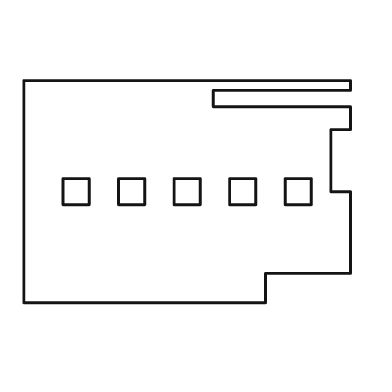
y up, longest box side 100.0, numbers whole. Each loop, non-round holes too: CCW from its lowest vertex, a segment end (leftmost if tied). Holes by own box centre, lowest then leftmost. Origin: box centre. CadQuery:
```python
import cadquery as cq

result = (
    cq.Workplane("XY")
    .moveTo(-50.0, -34.0)
    .lineTo(24.0, -34.0)
    .lineTo(24.0, -25.0)
    .lineTo(50.0, -25.0)
    .lineTo(50.0, 0.0)
    .lineTo(44.0, 0.0)
    .lineTo(44.0, 19.0)
    .lineTo(50.0, 19.0)
    .lineTo(50.0, 26.0)
    .lineTo(8.0, 26.0)
    .lineTo(8.0, 31.0)
    .lineTo(50.0, 31.0)
    .lineTo(50.0, 34.0)
    .lineTo(-50.0, 34.0)
    .close()
    .moveTo(-38.0, -4.0)
    .lineTo(-30.0, -4.0)
    .lineTo(-30.0, 4.0)
    .lineTo(-38.0, 4.0)
    .close()
    .moveTo(-21.0, -4.0)
    .lineTo(-13.0, -4.0)
    .lineTo(-13.0, 4.0)
    .lineTo(-21.0, 4.0)
    .close()
    .moveTo(-4.0, -4.0)
    .lineTo(4.0, -4.0)
    .lineTo(4.0, 4.0)
    .lineTo(-4.0, 4.0)
    .close()
    .moveTo(13.0, -4.0)
    .lineTo(21.0, -4.0)
    .lineTo(21.0, 4.0)
    .lineTo(13.0, 4.0)
    .close()
    .moveTo(30.0, -4.0)
    .lineTo(38.0, -4.0)
    .lineTo(38.0, 4.0)
    .lineTo(30.0, 4.0)
    .close()
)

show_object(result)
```